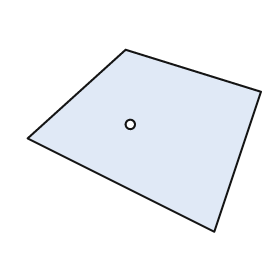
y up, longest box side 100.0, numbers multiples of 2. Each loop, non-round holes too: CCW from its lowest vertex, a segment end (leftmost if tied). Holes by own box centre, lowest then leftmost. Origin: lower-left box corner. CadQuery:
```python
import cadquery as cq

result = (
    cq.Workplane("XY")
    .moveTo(80.0, 0.0)
    .lineTo(100.0, 60.0)
    .lineTo(42.0, 78.0)
    .lineTo(0.0, 40.0)
    .close()
    .moveTo(44.0, 46.0)
    .circle(2.0)
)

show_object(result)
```